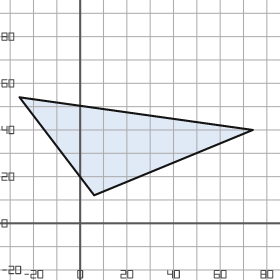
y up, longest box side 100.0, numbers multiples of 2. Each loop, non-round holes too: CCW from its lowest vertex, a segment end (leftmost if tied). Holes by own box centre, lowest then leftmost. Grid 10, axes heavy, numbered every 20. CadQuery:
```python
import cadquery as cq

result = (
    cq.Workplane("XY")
    .moveTo(6.0, 12.0)
    .lineTo(74.0, 40.0)
    .lineTo(-26.0, 54.0)
    .close()
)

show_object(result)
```